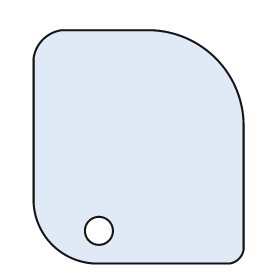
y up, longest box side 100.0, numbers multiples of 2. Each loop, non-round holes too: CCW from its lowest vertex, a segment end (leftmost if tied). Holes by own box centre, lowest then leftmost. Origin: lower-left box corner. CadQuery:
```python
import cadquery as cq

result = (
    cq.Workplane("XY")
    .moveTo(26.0, 0.0)
    .lineTo(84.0, 0.0)
    .threePointArc((88.0, 2.0), (90.0, 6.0))
    .lineTo(90.0, 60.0)
    .threePointArc((78.0, 88.0), (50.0, 100.0))
    .lineTo(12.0, 100.0)
    .threePointArc((4.0, 96.0), (0.0, 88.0))
    .lineTo(0.0, 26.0)
    .threePointArc((8.0, 8.0), (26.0, 0.0))
    .close()
    .moveTo(28.0, 14.0)
    .circle(6.0)
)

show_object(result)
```